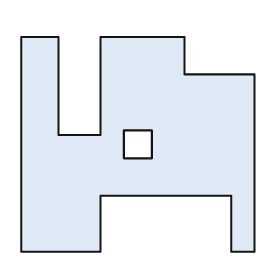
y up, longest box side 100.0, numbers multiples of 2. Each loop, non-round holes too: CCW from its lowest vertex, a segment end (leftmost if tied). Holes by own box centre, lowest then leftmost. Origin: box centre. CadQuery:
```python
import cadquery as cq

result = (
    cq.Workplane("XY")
    .moveTo(-50.0, -46.0)
    .lineTo(-16.0, -46.0)
    .lineTo(-16.0, -22.0)
    .lineTo(40.0, -22.0)
    .lineTo(40.0, -46.0)
    .lineTo(50.0, -46.0)
    .lineTo(50.0, 30.0)
    .lineTo(20.0, 30.0)
    .lineTo(20.0, 46.0)
    .lineTo(-16.0, 46.0)
    .lineTo(-16.0, 4.0)
    .lineTo(-34.0, 4.0)
    .lineTo(-34.0, 46.0)
    .lineTo(-50.0, 46.0)
    .close()
    .moveTo(-6.0, -6.0)
    .lineTo(6.0, -6.0)
    .lineTo(6.0, 6.0)
    .lineTo(-6.0, 6.0)
    .close()
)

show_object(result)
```